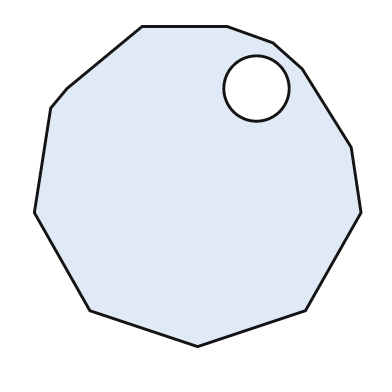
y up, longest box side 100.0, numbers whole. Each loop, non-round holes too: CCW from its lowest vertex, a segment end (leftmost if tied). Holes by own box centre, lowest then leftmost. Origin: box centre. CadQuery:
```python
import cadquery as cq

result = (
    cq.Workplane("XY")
    .moveTo(0.0, -49.0)
    .lineTo(33.0, -38.0)
    .lineTo(50.0, -8.0)
    .lineTo(47.0, 12.0)
    .lineTo(32.0, 36.0)
    .lineTo(23.0, 44.0)
    .lineTo(9.0, 49.0)
    .lineTo(-17.0, 49.0)
    .lineTo(-40.0, 30.0)
    .lineTo(-45.0, 24.0)
    .lineTo(-50.0, -8.0)
    .lineTo(-33.0, -38.0)
    .close()
    .moveTo(18.0, 30.0)
    .circle(10.0)
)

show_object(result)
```